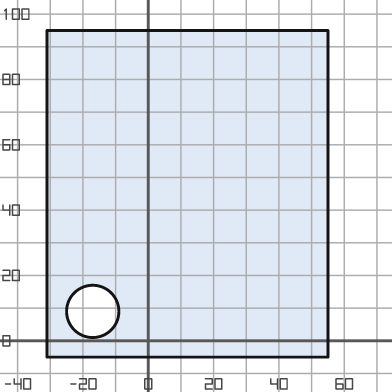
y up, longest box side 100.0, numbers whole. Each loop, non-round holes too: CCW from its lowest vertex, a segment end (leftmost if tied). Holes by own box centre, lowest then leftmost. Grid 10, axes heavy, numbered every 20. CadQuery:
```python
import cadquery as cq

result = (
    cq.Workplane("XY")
    .moveTo(-31.0, -5.0)
    .lineTo(55.0, -5.0)
    .lineTo(55.0, 95.0)
    .lineTo(-31.0, 95.0)
    .close()
    .moveTo(-17.0, 9.0)
    .circle(8.0)
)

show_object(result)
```